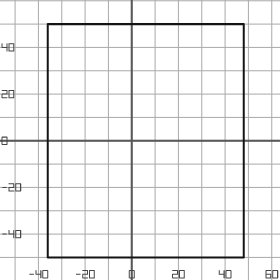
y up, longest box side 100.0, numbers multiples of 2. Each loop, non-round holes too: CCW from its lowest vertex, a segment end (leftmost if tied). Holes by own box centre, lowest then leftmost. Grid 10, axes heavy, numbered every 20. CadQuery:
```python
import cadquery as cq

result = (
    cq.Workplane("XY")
    .moveTo(-36.0, -50.0)
    .lineTo(48.0, -50.0)
    .lineTo(48.0, 50.0)
    .lineTo(-36.0, 50.0)
    .close()
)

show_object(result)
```